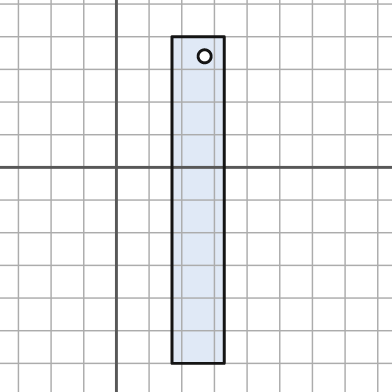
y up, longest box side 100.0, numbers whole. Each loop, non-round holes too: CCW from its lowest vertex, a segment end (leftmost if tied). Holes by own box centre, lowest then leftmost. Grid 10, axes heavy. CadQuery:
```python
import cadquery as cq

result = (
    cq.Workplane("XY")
    .moveTo(17.0, -60.0)
    .lineTo(33.0, -60.0)
    .lineTo(33.0, 40.0)
    .lineTo(17.0, 40.0)
    .close()
    .moveTo(27.0, 34.0)
    .circle(2.0)
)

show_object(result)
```